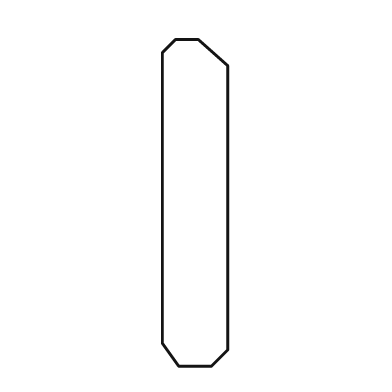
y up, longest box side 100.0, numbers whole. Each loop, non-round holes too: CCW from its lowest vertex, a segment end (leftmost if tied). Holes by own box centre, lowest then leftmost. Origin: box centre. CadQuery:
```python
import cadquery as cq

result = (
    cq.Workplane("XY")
    .moveTo(-5.0, -50.0)
    .lineTo(5.0, -50.0)
    .lineTo(10.0, -45.0)
    .lineTo(10.0, 42.0)
    .lineTo(1.0, 50.0)
    .lineTo(-6.0, 50.0)
    .lineTo(-10.0, 46.0)
    .lineTo(-10.0, -43.0)
    .close()
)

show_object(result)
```